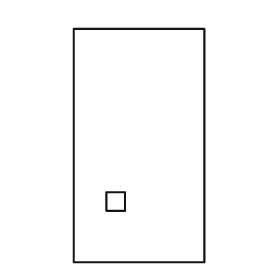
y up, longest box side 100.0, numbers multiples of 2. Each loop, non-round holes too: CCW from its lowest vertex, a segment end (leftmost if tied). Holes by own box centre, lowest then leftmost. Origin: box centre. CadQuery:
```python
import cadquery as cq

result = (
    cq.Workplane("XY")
    .moveTo(-28.0, -50.0)
    .lineTo(28.0, -50.0)
    .lineTo(28.0, 50.0)
    .lineTo(-28.0, 50.0)
    .close()
    .moveTo(-14.0, -28.0)
    .lineTo(-6.0, -28.0)
    .lineTo(-6.0, -20.0)
    .lineTo(-14.0, -20.0)
    .close()
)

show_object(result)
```